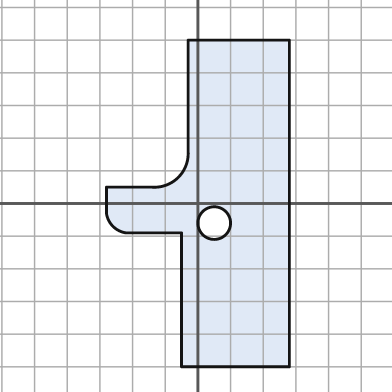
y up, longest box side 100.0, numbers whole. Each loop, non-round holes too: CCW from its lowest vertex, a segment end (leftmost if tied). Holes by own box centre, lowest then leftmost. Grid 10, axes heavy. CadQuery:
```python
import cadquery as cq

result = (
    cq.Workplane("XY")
    .moveTo(-5.0, -50.0)
    .lineTo(28.0, -50.0)
    .lineTo(28.0, 50.0)
    .lineTo(-3.0, 50.0)
    .lineTo(-3.0, 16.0)
    .threePointArc((-6.0, 8.0), (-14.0, 5.0))
    .lineTo(-28.0, 5.0)
    .lineTo(-28.0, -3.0)
    .threePointArc((-26.0, -7.0), (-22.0, -9.0))
    .lineTo(-5.0, -9.0)
    .close()
    .moveTo(5.0, -6.0)
    .circle(5.0)
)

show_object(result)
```